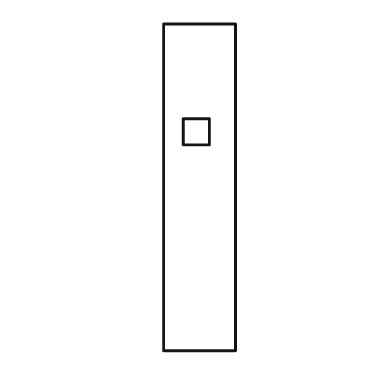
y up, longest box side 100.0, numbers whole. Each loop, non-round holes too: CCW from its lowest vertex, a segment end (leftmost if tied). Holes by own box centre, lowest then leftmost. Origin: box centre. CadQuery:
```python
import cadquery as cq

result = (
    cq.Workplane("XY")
    .moveTo(-11.0, -50.0)
    .lineTo(11.0, -50.0)
    .lineTo(11.0, 50.0)
    .lineTo(-11.0, 50.0)
    .close()
    .moveTo(-5.0, 13.0)
    .lineTo(3.0, 13.0)
    .lineTo(3.0, 21.0)
    .lineTo(-5.0, 21.0)
    .close()
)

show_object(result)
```